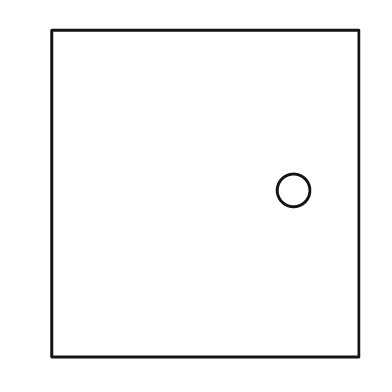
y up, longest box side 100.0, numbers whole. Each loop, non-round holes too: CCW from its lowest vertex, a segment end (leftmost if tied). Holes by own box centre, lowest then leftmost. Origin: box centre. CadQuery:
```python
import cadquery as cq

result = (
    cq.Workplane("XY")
    .moveTo(-47.0, -50.0)
    .lineTo(47.0, -50.0)
    .lineTo(47.0, 50.0)
    .lineTo(-47.0, 50.0)
    .close()
    .moveTo(27.0, 1.0)
    .circle(5.0)
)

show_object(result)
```